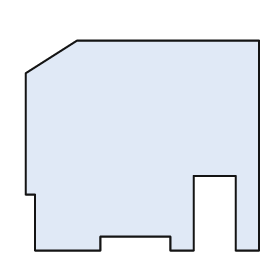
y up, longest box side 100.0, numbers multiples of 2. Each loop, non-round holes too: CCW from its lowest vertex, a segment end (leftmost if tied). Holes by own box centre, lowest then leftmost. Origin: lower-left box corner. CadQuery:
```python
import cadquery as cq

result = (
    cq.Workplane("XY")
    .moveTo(4.0, 0.0)
    .lineTo(32.0, 0.0)
    .lineTo(32.0, 6.0)
    .lineTo(62.0, 6.0)
    .lineTo(62.0, 0.0)
    .lineTo(72.0, 0.0)
    .lineTo(72.0, 32.0)
    .lineTo(90.0, 32.0)
    .lineTo(90.0, 0.0)
    .lineTo(100.0, 0.0)
    .lineTo(100.0, 90.0)
    .lineTo(22.0, 90.0)
    .lineTo(0.0, 76.0)
    .lineTo(0.0, 24.0)
    .lineTo(4.0, 24.0)
    .close()
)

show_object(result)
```